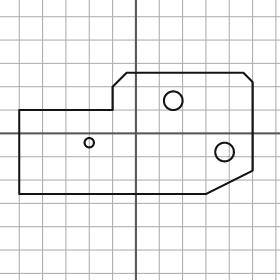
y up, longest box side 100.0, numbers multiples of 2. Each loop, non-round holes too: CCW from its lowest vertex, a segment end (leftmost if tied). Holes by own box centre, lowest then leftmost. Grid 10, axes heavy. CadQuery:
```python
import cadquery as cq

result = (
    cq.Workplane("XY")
    .moveTo(-50.0, -26.0)
    .lineTo(30.0, -26.0)
    .lineTo(50.0, -16.0)
    .lineTo(50.0, 22.0)
    .lineTo(46.0, 26.0)
    .lineTo(-4.0, 26.0)
    .lineTo(-10.0, 20.0)
    .lineTo(-10.0, 10.0)
    .lineTo(-50.0, 10.0)
    .close()
    .moveTo(38.0, -8.0)
    .circle(4.0)
    .moveTo(-20.0, -4.0)
    .circle(2.0)
    .moveTo(16.0, 14.0)
    .circle(4.0)
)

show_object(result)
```